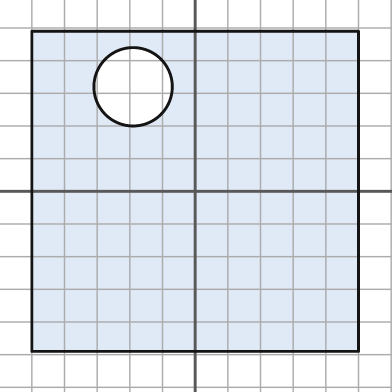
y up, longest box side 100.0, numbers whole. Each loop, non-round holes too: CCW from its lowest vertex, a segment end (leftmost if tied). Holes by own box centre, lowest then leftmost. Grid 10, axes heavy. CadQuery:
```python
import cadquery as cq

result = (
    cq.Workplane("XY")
    .moveTo(-50.0, -49.0)
    .lineTo(50.0, -49.0)
    .lineTo(50.0, 49.0)
    .lineTo(-50.0, 49.0)
    .close()
    .moveTo(-19.0, 32.0)
    .circle(12.0)
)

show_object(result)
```